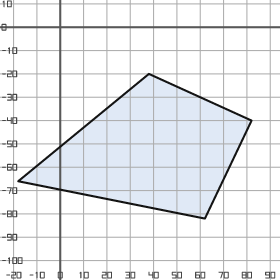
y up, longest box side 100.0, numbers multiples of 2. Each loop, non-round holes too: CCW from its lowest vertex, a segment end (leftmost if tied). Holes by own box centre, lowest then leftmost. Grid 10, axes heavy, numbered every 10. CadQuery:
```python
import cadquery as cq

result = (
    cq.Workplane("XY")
    .moveTo(62.0, -82.0)
    .lineTo(82.0, -40.0)
    .lineTo(38.0, -20.0)
    .lineTo(-18.0, -66.0)
    .close()
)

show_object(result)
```